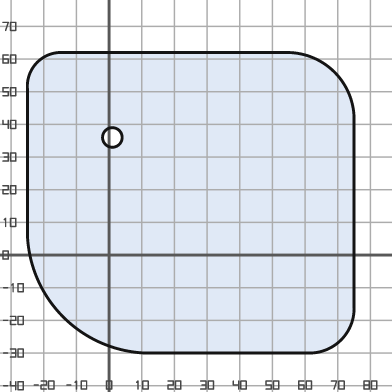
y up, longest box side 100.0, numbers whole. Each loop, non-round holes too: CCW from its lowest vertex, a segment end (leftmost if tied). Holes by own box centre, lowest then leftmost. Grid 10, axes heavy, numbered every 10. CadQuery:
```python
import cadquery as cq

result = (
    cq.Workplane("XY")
    .moveTo(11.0, -30.0)
    .lineTo(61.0, -30.0)
    .threePointArc((71.0, -26.0), (75.0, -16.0))
    .lineTo(75.0, 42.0)
    .threePointArc((69.0, 56.0), (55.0, 62.0))
    .lineTo(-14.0, 62.0)
    .threePointArc((-22.0, 59.0), (-25.0, 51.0))
    .lineTo(-25.0, 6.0)
    .threePointArc((-14.0, -19.0), (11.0, -30.0))
    .close()
    .moveTo(1.0, 36.0)
    .circle(3.0)
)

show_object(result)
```